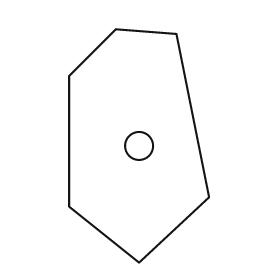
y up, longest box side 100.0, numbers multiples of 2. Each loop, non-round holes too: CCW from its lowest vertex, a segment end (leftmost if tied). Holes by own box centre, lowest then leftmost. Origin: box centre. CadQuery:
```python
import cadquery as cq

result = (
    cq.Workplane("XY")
    .moveTo(0.0, -50.0)
    .lineTo(30.0, -22.0)
    .lineTo(16.0, 48.0)
    .lineTo(-10.0, 50.0)
    .lineTo(-30.0, 30.0)
    .lineTo(-30.0, -26.0)
    .close()
    .moveTo(0.0, 0.0)
    .circle(6.0)
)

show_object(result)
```